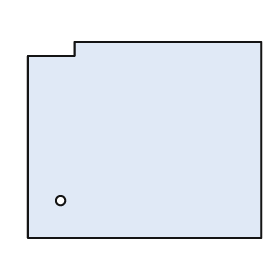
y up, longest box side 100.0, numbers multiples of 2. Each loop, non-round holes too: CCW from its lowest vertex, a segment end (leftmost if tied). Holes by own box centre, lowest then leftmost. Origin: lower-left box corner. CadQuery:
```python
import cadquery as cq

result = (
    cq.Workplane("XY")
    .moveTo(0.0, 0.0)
    .lineTo(100.0, 0.0)
    .lineTo(100.0, 84.0)
    .lineTo(20.0, 84.0)
    .lineTo(20.0, 78.0)
    .lineTo(0.0, 78.0)
    .close()
    .moveTo(14.0, 16.0)
    .circle(2.0)
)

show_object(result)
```